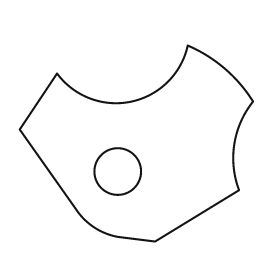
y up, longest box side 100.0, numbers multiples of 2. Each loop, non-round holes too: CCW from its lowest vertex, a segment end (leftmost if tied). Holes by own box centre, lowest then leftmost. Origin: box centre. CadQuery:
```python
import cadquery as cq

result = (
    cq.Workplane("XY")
    .moveTo(8.0, -42.0)
    .lineTo(44.0, -20.0)
    .threePointArc((42.0, 0.0), (50.0, 18.0))
    .threePointArc((38.0, 32.0), (22.0, 42.0))
    .threePointArc((-2.0, 18.0), (-34.0, 30.0))
    .lineTo(-50.0, 6.0)
    .lineTo(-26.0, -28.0)
    .threePointArc((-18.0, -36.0), (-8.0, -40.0))
    .close()
    .moveTo(-8.0, -12.0)
    .circle(10.0)
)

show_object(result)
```